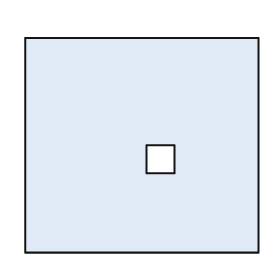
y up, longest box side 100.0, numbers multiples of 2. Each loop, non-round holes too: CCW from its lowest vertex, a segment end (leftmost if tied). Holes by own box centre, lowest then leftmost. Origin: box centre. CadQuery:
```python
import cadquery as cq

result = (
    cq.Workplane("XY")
    .moveTo(-50.0, -46.0)
    .lineTo(50.0, -46.0)
    .lineTo(50.0, 46.0)
    .lineTo(-50.0, 46.0)
    .close()
    .moveTo(2.0, -12.0)
    .lineTo(14.0, -12.0)
    .lineTo(14.0, 0.0)
    .lineTo(2.0, 0.0)
    .close()
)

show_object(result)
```